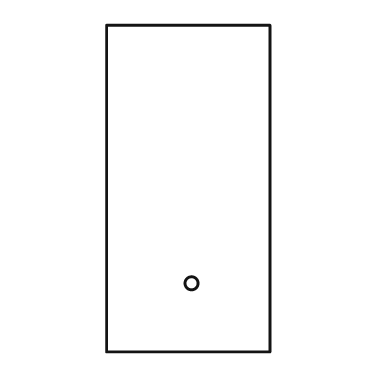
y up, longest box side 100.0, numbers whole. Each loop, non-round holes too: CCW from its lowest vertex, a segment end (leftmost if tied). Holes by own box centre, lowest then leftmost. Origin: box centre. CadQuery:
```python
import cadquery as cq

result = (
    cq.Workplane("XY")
    .moveTo(-25.0, -50.0)
    .lineTo(25.0, -50.0)
    .lineTo(25.0, 50.0)
    .lineTo(-25.0, 50.0)
    .close()
    .moveTo(1.0, -29.0)
    .circle(2.0)
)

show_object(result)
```